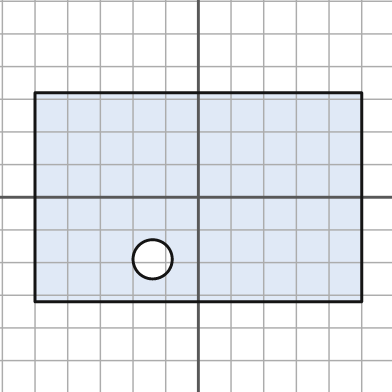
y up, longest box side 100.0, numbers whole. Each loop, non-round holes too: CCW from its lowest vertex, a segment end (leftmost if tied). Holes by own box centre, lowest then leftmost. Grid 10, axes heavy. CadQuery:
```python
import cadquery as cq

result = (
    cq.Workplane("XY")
    .moveTo(-50.0, -32.0)
    .lineTo(50.0, -32.0)
    .lineTo(50.0, 32.0)
    .lineTo(-50.0, 32.0)
    .close()
    .moveTo(-14.0, -19.0)
    .circle(6.0)
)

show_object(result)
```